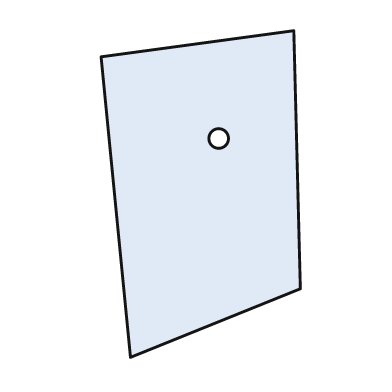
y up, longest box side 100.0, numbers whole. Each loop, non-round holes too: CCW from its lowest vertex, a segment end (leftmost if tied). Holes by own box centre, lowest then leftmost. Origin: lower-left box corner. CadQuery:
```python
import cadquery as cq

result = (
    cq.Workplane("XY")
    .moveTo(9.0, 0.0)
    .lineTo(61.0, 21.0)
    .lineTo(59.0, 100.0)
    .lineTo(0.0, 92.0)
    .close()
    .moveTo(36.0, 67.0)
    .circle(3.0)
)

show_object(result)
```